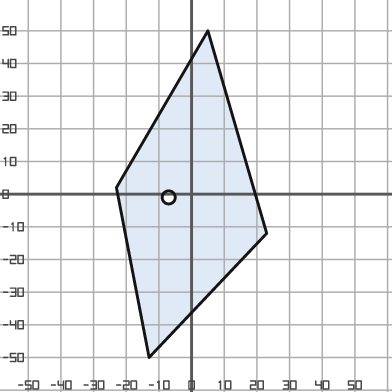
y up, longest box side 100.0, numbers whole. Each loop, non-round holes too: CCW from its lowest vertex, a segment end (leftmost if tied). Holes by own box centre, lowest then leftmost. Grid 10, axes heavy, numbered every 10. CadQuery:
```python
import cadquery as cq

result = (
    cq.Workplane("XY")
    .moveTo(-13.0, -50.0)
    .lineTo(23.0, -12.0)
    .lineTo(5.0, 50.0)
    .lineTo(-23.0, 2.0)
    .close()
    .moveTo(-7.0, -1.0)
    .circle(2.0)
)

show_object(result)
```